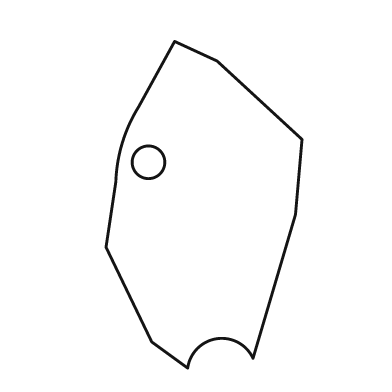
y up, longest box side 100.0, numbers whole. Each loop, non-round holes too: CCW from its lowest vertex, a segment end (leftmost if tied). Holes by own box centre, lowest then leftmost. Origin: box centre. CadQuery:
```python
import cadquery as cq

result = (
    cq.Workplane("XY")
    .moveTo(-5.0, -50.0)
    .threePointArc((4.0, -41.0), (15.0, -47.0))
    .lineTo(28.0, -3.0)
    .lineTo(30.0, 20.0)
    .lineTo(4.0, 44.0)
    .lineTo(-9.0, 50.0)
    .lineTo(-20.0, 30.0)
    .threePointArc((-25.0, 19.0), (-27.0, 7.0))
    .lineTo(-30.0, -13.0)
    .lineTo(-16.0, -42.0)
    .close()
    .moveTo(-17.0, 13.0)
    .circle(5.0)
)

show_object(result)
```